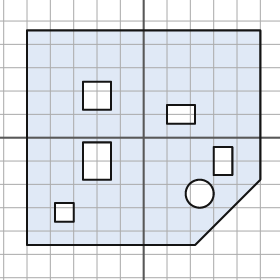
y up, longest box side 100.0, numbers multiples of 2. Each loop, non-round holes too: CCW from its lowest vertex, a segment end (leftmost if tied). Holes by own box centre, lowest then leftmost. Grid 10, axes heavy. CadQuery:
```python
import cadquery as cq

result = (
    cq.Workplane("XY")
    .moveTo(-50.0, -46.0)
    .lineTo(22.0, -46.0)
    .lineTo(50.0, -18.0)
    .lineTo(50.0, 46.0)
    .lineTo(-50.0, 46.0)
    .close()
    .moveTo(-38.0, -36.0)
    .lineTo(-30.0, -36.0)
    .lineTo(-30.0, -28.0)
    .lineTo(-38.0, -28.0)
    .close()
    .moveTo(24.0, -24.0)
    .circle(6.0)
    .moveTo(-26.0, -18.0)
    .lineTo(-14.0, -18.0)
    .lineTo(-14.0, -2.0)
    .lineTo(-26.0, -2.0)
    .close()
    .moveTo(30.0, -16.0)
    .lineTo(38.0, -16.0)
    .lineTo(38.0, -4.0)
    .lineTo(30.0, -4.0)
    .close()
    .moveTo(10.0, 6.0)
    .lineTo(22.0, 6.0)
    .lineTo(22.0, 14.0)
    .lineTo(10.0, 14.0)
    .close()
    .moveTo(-26.0, 12.0)
    .lineTo(-14.0, 12.0)
    .lineTo(-14.0, 24.0)
    .lineTo(-26.0, 24.0)
    .close()
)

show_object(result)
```